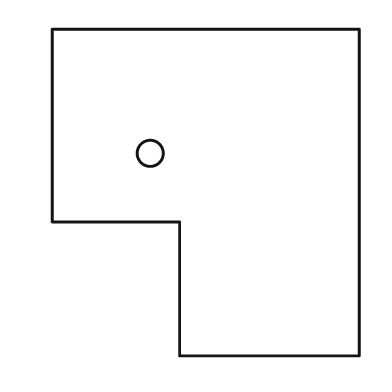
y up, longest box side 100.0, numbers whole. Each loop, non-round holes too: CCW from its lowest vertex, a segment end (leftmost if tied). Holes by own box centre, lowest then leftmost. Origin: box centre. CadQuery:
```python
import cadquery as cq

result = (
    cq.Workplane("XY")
    .moveTo(-8.0, -50.0)
    .lineTo(47.0, -50.0)
    .lineTo(47.0, 50.0)
    .lineTo(-47.0, 50.0)
    .lineTo(-47.0, -9.0)
    .lineTo(-8.0, -9.0)
    .close()
    .moveTo(-17.0, 12.0)
    .circle(4.0)
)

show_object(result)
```